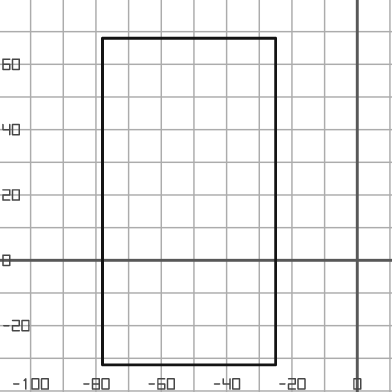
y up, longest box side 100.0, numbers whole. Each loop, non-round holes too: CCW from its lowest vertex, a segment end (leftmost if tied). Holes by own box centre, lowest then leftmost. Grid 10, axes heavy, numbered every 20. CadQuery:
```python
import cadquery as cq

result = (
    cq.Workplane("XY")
    .moveTo(-78.0, -32.0)
    .lineTo(-25.0, -32.0)
    .lineTo(-25.0, 68.0)
    .lineTo(-78.0, 68.0)
    .close()
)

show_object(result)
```